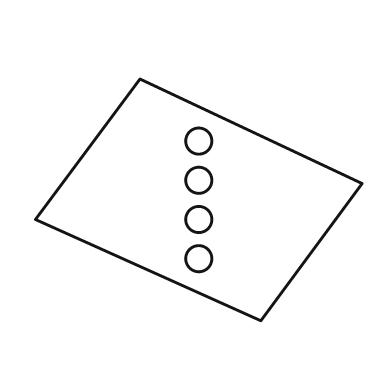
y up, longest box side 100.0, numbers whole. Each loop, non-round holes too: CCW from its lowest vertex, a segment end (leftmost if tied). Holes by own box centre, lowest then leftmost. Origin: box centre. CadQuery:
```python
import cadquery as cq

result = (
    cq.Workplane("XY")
    .moveTo(19.0, -37.0)
    .lineTo(50.0, 5.0)
    .lineTo(-18.0, 37.0)
    .lineTo(-50.0, -6.0)
    .close()
    .moveTo(0.0, -18.0)
    .circle(4.0)
    .moveTo(0.0, -6.0)
    .circle(4.0)
    .moveTo(0.0, 6.0)
    .circle(4.0)
    .moveTo(0.0, 18.0)
    .circle(4.0)
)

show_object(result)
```